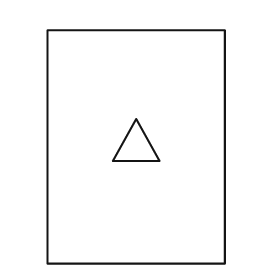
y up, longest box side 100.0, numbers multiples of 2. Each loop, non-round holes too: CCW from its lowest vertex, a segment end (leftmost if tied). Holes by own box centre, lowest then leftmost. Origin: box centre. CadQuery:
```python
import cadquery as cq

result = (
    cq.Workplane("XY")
    .moveTo(-38.0, -50.0)
    .lineTo(38.0, -50.0)
    .lineTo(38.0, 50.0)
    .lineTo(-38.0, 50.0)
    .close()
    .moveTo(-10.0, -6.0)
    .lineTo(10.0, -6.0)
    .lineTo(0.0, 12.0)
    .close()
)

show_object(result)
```